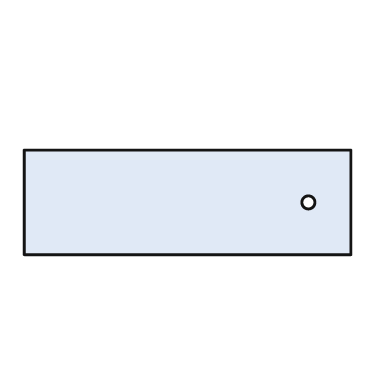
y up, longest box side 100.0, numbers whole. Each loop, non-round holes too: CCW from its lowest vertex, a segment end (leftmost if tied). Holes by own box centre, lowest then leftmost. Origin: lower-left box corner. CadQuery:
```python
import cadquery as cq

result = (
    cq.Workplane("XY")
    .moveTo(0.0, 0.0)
    .lineTo(100.0, 0.0)
    .lineTo(100.0, 32.0)
    .lineTo(0.0, 32.0)
    .close()
    .moveTo(87.0, 16.0)
    .circle(2.0)
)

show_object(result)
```